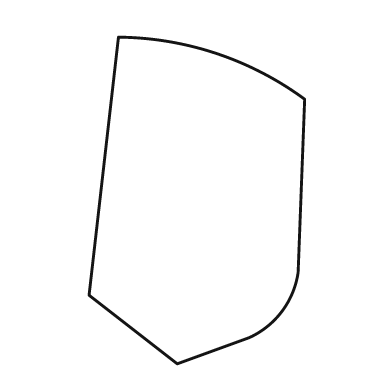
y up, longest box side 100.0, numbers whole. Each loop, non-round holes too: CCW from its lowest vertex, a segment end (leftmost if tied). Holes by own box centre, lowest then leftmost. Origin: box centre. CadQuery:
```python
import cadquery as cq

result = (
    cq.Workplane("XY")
    .moveTo(-6.0, -50.0)
    .lineTo(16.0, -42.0)
    .threePointArc((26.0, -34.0), (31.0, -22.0))
    .lineTo(33.0, 31.0)
    .threePointArc((6.0, 45.0), (-24.0, 50.0))
    .lineTo(-33.0, -29.0)
    .close()
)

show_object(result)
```